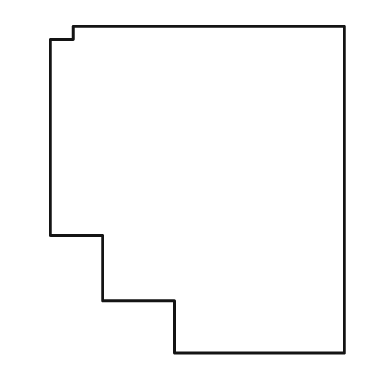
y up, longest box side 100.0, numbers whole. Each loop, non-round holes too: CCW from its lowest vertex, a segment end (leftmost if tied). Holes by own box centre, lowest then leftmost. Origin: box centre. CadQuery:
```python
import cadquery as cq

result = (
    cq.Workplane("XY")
    .moveTo(-7.0, -50.0)
    .lineTo(45.0, -50.0)
    .lineTo(45.0, 50.0)
    .lineTo(-38.0, 50.0)
    .lineTo(-38.0, 46.0)
    .lineTo(-45.0, 46.0)
    .lineTo(-45.0, -14.0)
    .lineTo(-29.0, -14.0)
    .lineTo(-29.0, -34.0)
    .lineTo(-7.0, -34.0)
    .close()
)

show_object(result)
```